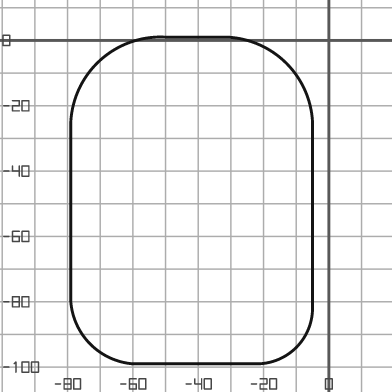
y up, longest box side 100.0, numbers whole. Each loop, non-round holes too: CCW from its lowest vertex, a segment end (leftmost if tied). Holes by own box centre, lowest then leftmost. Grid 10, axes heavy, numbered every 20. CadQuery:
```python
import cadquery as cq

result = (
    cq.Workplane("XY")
    .moveTo(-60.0, -99.0)
    .lineTo(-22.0, -99.0)
    .threePointArc((-10.0, -94.0), (-5.0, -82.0))
    .lineTo(-5.0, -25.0)
    .threePointArc((-13.0, -7.0), (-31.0, 1.0))
    .lineTo(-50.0, 1.0)
    .threePointArc((-71.0, -7.0), (-79.0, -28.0))
    .lineTo(-79.0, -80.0)
    .threePointArc((-73.0, -93.0), (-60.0, -99.0))
    .close()
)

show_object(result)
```